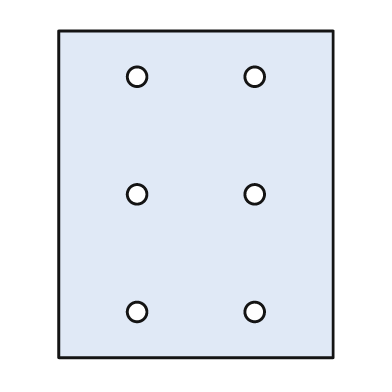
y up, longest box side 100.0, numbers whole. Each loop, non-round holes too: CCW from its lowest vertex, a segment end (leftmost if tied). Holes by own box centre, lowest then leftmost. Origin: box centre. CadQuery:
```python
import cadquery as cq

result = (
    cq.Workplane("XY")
    .moveTo(-42.0, -50.0)
    .lineTo(42.0, -50.0)
    .lineTo(42.0, 50.0)
    .lineTo(-42.0, 50.0)
    .close()
    .moveTo(-18.0, -36.0)
    .circle(3.0)
    .moveTo(18.0, -36.0)
    .circle(3.0)
    .moveTo(-18.0, 0.0)
    .circle(3.0)
    .moveTo(18.0, 0.0)
    .circle(3.0)
    .moveTo(-18.0, 36.0)
    .circle(3.0)
    .moveTo(18.0, 36.0)
    .circle(3.0)
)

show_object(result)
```